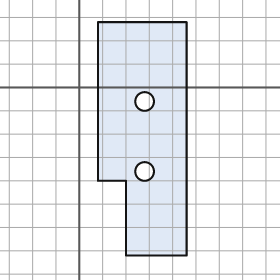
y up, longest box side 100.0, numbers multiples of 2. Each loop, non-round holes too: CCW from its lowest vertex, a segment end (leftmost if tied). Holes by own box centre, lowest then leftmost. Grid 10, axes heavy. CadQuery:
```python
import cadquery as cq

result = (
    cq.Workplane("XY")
    .moveTo(20.0, -72.0)
    .lineTo(46.0, -72.0)
    .lineTo(46.0, 28.0)
    .lineTo(8.0, 28.0)
    .lineTo(8.0, -40.0)
    .lineTo(20.0, -40.0)
    .close()
    .moveTo(28.0, -36.0)
    .circle(4.0)
    .moveTo(28.0, -6.0)
    .circle(4.0)
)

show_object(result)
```